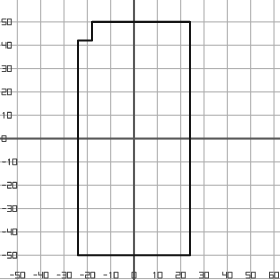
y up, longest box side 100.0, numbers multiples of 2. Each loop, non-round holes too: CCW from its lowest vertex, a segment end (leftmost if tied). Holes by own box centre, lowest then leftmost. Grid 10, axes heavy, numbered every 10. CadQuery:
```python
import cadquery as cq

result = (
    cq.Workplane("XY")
    .moveTo(-24.0, -50.0)
    .lineTo(24.0, -50.0)
    .lineTo(24.0, 50.0)
    .lineTo(-18.0, 50.0)
    .lineTo(-18.0, 42.0)
    .lineTo(-24.0, 42.0)
    .close()
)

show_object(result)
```